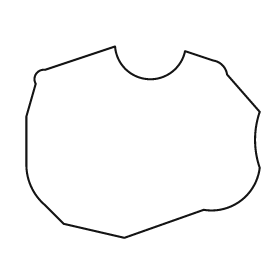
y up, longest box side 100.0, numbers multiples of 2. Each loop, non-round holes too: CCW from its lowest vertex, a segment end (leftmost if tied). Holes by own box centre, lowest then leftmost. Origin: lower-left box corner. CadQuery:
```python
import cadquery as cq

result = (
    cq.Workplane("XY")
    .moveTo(42.0, 0.0)
    .lineTo(76.0, 12.0)
    .threePointArc((92.0, 16.0), (100.0, 30.0))
    .threePointArc((98.0, 42.0), (100.0, 54.0))
    .lineTo(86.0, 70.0)
    .threePointArc((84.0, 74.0), (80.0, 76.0))
    .lineTo(68.0, 80.0)
    .threePointArc((52.0, 68.0), (38.0, 82.0))
    .lineTo(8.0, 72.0)
    .threePointArc((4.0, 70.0), (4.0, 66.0))
    .lineTo(0.0, 52.0)
    .lineTo(0.0, 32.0)
    .threePointArc((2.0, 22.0), (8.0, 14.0))
    .lineTo(16.0, 6.0)
    .close()
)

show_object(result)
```